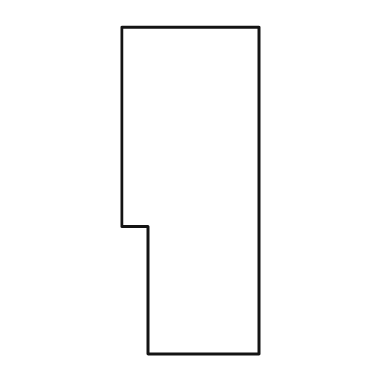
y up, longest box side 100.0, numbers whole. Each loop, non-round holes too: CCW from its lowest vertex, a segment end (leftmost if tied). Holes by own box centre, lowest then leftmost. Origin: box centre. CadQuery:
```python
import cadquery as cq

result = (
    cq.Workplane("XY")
    .moveTo(-13.0, -50.0)
    .lineTo(21.0, -50.0)
    .lineTo(21.0, 50.0)
    .lineTo(-21.0, 50.0)
    .lineTo(-21.0, -11.0)
    .lineTo(-13.0, -11.0)
    .close()
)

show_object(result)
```